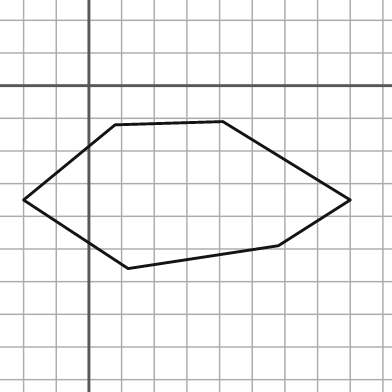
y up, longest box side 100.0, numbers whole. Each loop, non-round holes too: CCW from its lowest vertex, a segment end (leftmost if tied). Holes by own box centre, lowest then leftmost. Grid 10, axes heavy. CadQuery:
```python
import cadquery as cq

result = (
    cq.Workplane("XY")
    .moveTo(12.0, -56.0)
    .lineTo(58.0, -49.0)
    .lineTo(80.0, -35.0)
    .lineTo(41.0, -11.0)
    .lineTo(8.0, -12.0)
    .lineTo(-20.0, -35.0)
    .close()
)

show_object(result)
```